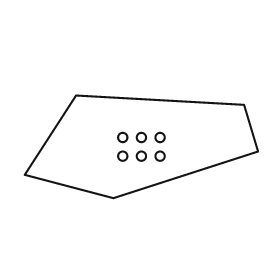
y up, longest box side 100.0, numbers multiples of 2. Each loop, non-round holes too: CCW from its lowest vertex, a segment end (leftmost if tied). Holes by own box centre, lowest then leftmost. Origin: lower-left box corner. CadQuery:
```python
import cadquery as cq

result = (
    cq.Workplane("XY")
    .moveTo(38.0, 0.0)
    .lineTo(100.0, 20.0)
    .lineTo(94.0, 40.0)
    .lineTo(22.0, 44.0)
    .lineTo(0.0, 10.0)
    .close()
    .moveTo(42.0, 18.0)
    .circle(2.0)
    .moveTo(50.0, 18.0)
    .circle(2.0)
    .moveTo(58.0, 18.0)
    .circle(2.0)
    .moveTo(42.0, 26.0)
    .circle(2.0)
    .moveTo(50.0, 26.0)
    .circle(2.0)
    .moveTo(58.0, 26.0)
    .circle(2.0)
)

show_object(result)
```